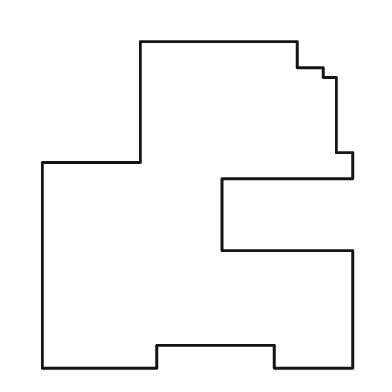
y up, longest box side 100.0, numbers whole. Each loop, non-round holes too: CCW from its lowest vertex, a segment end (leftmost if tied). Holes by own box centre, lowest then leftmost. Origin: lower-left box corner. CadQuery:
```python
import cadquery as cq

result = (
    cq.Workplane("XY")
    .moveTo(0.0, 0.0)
    .lineTo(35.0, 0.0)
    .lineTo(35.0, 7.0)
    .lineTo(71.0, 7.0)
    .lineTo(71.0, 0.0)
    .lineTo(95.0, 0.0)
    .lineTo(95.0, 36.0)
    .lineTo(55.0, 36.0)
    .lineTo(55.0, 58.0)
    .lineTo(95.0, 58.0)
    .lineTo(95.0, 66.0)
    .lineTo(90.0, 66.0)
    .lineTo(90.0, 89.0)
    .lineTo(86.0, 89.0)
    .lineTo(86.0, 92.0)
    .lineTo(78.0, 92.0)
    .lineTo(78.0, 100.0)
    .lineTo(30.0, 100.0)
    .lineTo(30.0, 63.0)
    .lineTo(0.0, 63.0)
    .close()
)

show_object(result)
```